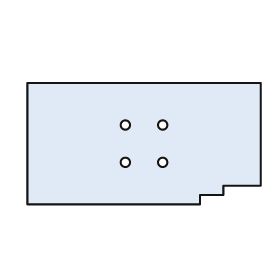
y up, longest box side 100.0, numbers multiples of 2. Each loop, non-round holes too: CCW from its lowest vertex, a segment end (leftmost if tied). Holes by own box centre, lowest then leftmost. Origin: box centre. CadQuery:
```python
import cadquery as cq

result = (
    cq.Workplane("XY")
    .moveTo(-50.0, -26.0)
    .lineTo(24.0, -26.0)
    .lineTo(24.0, -22.0)
    .lineTo(34.0, -22.0)
    .lineTo(34.0, -18.0)
    .lineTo(50.0, -18.0)
    .lineTo(50.0, 26.0)
    .lineTo(-50.0, 26.0)
    .close()
    .moveTo(-8.0, -8.0)
    .circle(2.0)
    .moveTo(8.0, -8.0)
    .circle(2.0)
    .moveTo(-8.0, 8.0)
    .circle(2.0)
    .moveTo(8.0, 8.0)
    .circle(2.0)
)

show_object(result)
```